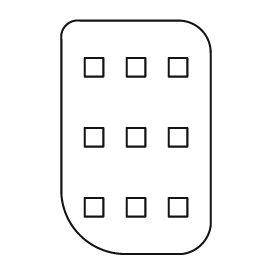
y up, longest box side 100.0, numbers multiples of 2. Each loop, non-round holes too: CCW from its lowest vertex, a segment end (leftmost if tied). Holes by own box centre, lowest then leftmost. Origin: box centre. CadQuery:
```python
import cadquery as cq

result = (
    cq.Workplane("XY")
    .moveTo(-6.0, -50.0)
    .lineTo(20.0, -50.0)
    .threePointArc((28.0, -46.0), (32.0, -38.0))
    .lineTo(32.0, 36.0)
    .threePointArc((28.0, 46.0), (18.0, 50.0))
    .lineTo(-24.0, 50.0)
    .threePointArc((-30.0, 48.0), (-32.0, 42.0))
    .lineTo(-32.0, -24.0)
    .threePointArc((-24.0, -42.0), (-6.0, -50.0))
    .close()
    .moveTo(-22.0, -34.0)
    .lineTo(-14.0, -34.0)
    .lineTo(-14.0, -26.0)
    .lineTo(-22.0, -26.0)
    .close()
    .moveTo(-4.0, -34.0)
    .lineTo(4.0, -34.0)
    .lineTo(4.0, -26.0)
    .lineTo(-4.0, -26.0)
    .close()
    .moveTo(14.0, -34.0)
    .lineTo(22.0, -34.0)
    .lineTo(22.0, -26.0)
    .lineTo(14.0, -26.0)
    .close()
    .moveTo(-22.0, -4.0)
    .lineTo(-14.0, -4.0)
    .lineTo(-14.0, 4.0)
    .lineTo(-22.0, 4.0)
    .close()
    .moveTo(-4.0, -4.0)
    .lineTo(4.0, -4.0)
    .lineTo(4.0, 4.0)
    .lineTo(-4.0, 4.0)
    .close()
    .moveTo(14.0, -4.0)
    .lineTo(22.0, -4.0)
    .lineTo(22.0, 4.0)
    .lineTo(14.0, 4.0)
    .close()
    .moveTo(-22.0, 26.0)
    .lineTo(-14.0, 26.0)
    .lineTo(-14.0, 34.0)
    .lineTo(-22.0, 34.0)
    .close()
    .moveTo(-4.0, 26.0)
    .lineTo(4.0, 26.0)
    .lineTo(4.0, 34.0)
    .lineTo(-4.0, 34.0)
    .close()
    .moveTo(14.0, 26.0)
    .lineTo(22.0, 26.0)
    .lineTo(22.0, 34.0)
    .lineTo(14.0, 34.0)
    .close()
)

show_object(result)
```